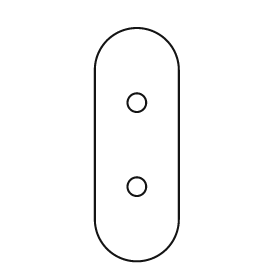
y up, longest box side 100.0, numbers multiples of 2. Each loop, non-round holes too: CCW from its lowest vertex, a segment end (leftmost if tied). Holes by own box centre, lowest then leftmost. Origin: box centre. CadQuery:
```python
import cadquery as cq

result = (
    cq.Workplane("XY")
    .moveTo(-18.0, -32.0)
    .threePointArc((0.0, -50.0), (18.0, -32.0))
    .lineTo(18.0, 32.0)
    .threePointArc((0.0, 50.0), (-18.0, 32.0))
    .close()
    .moveTo(0.0, -18.0)
    .circle(4.0)
    .moveTo(0.0, 18.0)
    .circle(4.0)
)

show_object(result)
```